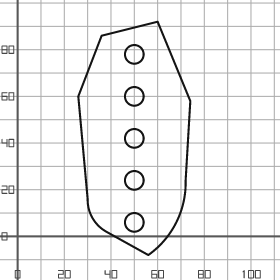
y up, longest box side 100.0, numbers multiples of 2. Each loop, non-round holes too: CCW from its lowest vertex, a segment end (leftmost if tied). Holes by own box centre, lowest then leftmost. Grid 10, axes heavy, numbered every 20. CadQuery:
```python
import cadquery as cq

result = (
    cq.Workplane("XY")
    .moveTo(56.0, -8.0)
    .threePointArc((68.0, 6.0), (72.0, 24.0))
    .lineTo(74.0, 58.0)
    .lineTo(60.0, 92.0)
    .lineTo(36.0, 86.0)
    .lineTo(26.0, 60.0)
    .lineTo(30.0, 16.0)
    .threePointArc((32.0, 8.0), (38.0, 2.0))
    .close()
    .moveTo(50.0, 6.0)
    .circle(4.0)
    .moveTo(50.0, 24.0)
    .circle(4.0)
    .moveTo(50.0, 42.0)
    .circle(4.0)
    .moveTo(50.0, 60.0)
    .circle(4.0)
    .moveTo(50.0, 78.0)
    .circle(4.0)
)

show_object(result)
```